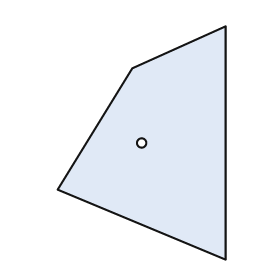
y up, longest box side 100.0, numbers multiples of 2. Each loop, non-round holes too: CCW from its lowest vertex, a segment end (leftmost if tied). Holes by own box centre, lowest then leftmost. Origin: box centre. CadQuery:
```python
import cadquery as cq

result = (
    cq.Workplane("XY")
    .moveTo(36.0, -50.0)
    .lineTo(36.0, 50.0)
    .lineTo(-4.0, 32.0)
    .lineTo(-36.0, -20.0)
    .close()
    .moveTo(0.0, 0.0)
    .circle(2.0)
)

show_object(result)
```